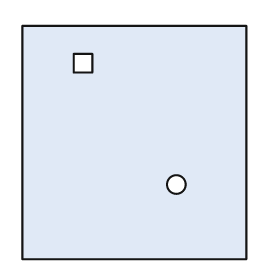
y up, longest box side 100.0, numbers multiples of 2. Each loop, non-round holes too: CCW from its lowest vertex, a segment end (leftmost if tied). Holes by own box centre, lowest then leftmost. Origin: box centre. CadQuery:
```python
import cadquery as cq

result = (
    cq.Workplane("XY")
    .moveTo(-48.0, -50.0)
    .lineTo(48.0, -50.0)
    .lineTo(48.0, 50.0)
    .lineTo(-48.0, 50.0)
    .close()
    .moveTo(18.0, -18.0)
    .circle(4.0)
    .moveTo(-26.0, 30.0)
    .lineTo(-18.0, 30.0)
    .lineTo(-18.0, 38.0)
    .lineTo(-26.0, 38.0)
    .close()
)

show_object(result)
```